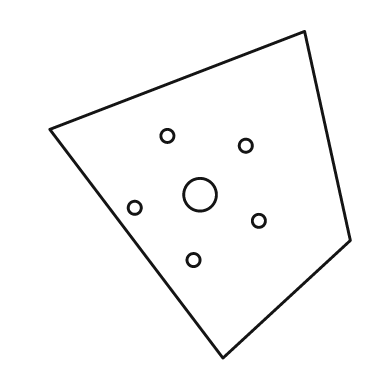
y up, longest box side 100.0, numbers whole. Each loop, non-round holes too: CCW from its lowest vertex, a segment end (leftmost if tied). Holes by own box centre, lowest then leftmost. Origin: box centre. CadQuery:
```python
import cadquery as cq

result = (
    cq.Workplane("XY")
    .moveTo(7.0, -50.0)
    .lineTo(46.0, -14.0)
    .lineTo(32.0, 50.0)
    .lineTo(-46.0, 20.0)
    .close()
    .moveTo(-2.0, -20.0)
    .circle(2.0)
    .moveTo(18.0, -8.0)
    .circle(2.0)
    .moveTo(-20.0, -4.0)
    .circle(2.0)
    .moveTo(0.0, 0.0)
    .circle(5.0)
    .moveTo(14.0, 15.0)
    .circle(2.0)
    .moveTo(-10.0, 18.0)
    .circle(2.0)
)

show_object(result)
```